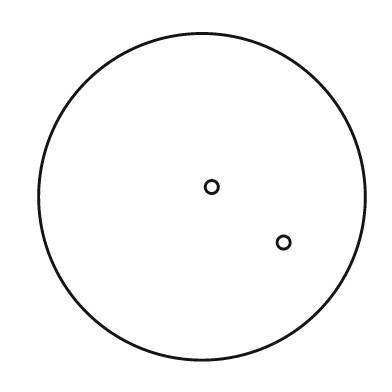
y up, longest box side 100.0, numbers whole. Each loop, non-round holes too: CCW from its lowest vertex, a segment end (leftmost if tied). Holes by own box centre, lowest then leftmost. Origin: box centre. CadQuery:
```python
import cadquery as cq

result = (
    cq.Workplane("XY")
    .moveTo(0.0, 0.0)
    .circle(50.0)
    .moveTo(25.0, -14.0)
    .circle(2.0)
    .moveTo(3.0, 3.0)
    .circle(2.0)
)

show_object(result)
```